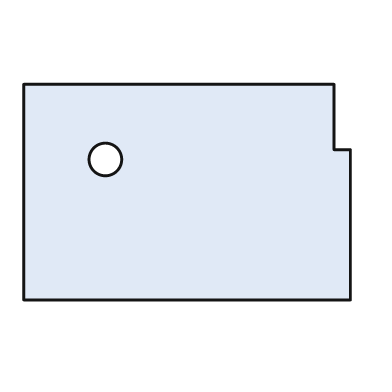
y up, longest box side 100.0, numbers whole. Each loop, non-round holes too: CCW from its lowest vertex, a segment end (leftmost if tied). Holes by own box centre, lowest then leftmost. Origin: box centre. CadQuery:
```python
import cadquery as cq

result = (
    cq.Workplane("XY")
    .moveTo(-50.0, -33.0)
    .lineTo(50.0, -33.0)
    .lineTo(50.0, 13.0)
    .lineTo(45.0, 13.0)
    .lineTo(45.0, 33.0)
    .lineTo(-50.0, 33.0)
    .close()
    .moveTo(-25.0, 10.0)
    .circle(5.0)
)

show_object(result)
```